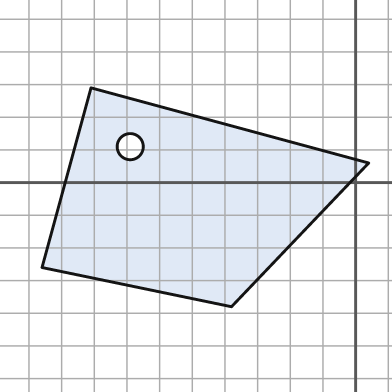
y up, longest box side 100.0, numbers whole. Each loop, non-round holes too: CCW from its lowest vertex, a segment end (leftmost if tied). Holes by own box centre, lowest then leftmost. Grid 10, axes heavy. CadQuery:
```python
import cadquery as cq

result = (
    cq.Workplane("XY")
    .moveTo(-38.0, -38.0)
    .lineTo(4.0, 6.0)
    .lineTo(-81.0, 29.0)
    .lineTo(-96.0, -26.0)
    .close()
    .moveTo(-69.0, 11.0)
    .circle(4.0)
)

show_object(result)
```